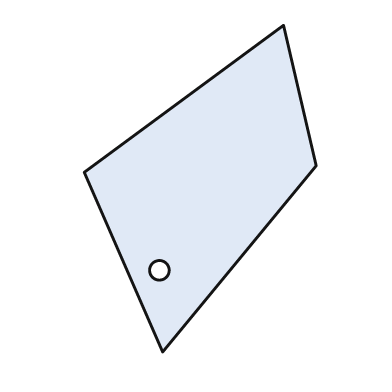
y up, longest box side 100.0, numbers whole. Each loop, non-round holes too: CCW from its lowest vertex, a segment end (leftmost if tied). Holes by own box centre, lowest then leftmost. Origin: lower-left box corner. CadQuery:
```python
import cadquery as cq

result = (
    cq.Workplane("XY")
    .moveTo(24.0, 0.0)
    .lineTo(71.0, 57.0)
    .lineTo(61.0, 100.0)
    .lineTo(0.0, 55.0)
    .close()
    .moveTo(23.0, 25.0)
    .circle(3.0)
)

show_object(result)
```